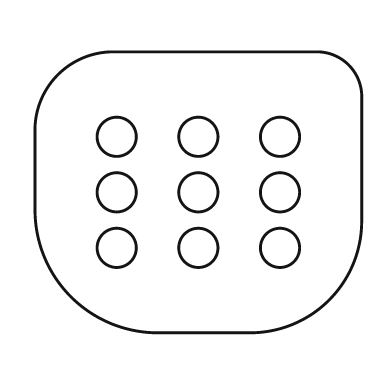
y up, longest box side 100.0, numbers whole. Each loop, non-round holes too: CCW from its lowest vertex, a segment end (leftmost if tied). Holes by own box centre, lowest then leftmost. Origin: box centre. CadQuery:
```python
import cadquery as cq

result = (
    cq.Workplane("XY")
    .moveTo(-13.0, -43.0)
    .lineTo(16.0, -43.0)
    .threePointArc((40.0, -33.0), (50.0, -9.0))
    .lineTo(50.0, 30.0)
    .threePointArc((46.0, 39.0), (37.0, 43.0))
    .lineTo(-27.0, 43.0)
    .threePointArc((-43.0, 36.0), (-50.0, 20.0))
    .lineTo(-50.0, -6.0)
    .threePointArc((-39.0, -32.0), (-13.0, -43.0))
    .close()
    .moveTo(-25.0, -17.0)
    .circle(6.0)
    .moveTo(0.0, -17.0)
    .circle(6.0)
    .moveTo(25.0, -17.0)
    .circle(6.0)
    .moveTo(-25.0, 0.0)
    .circle(6.0)
    .moveTo(0.0, 0.0)
    .circle(6.0)
    .moveTo(25.0, 0.0)
    .circle(6.0)
    .moveTo(-25.0, 17.0)
    .circle(6.0)
    .moveTo(0.0, 17.0)
    .circle(6.0)
    .moveTo(25.0, 17.0)
    .circle(6.0)
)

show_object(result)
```